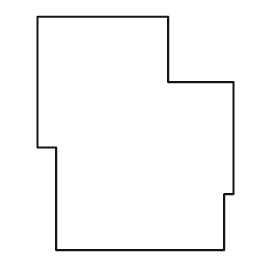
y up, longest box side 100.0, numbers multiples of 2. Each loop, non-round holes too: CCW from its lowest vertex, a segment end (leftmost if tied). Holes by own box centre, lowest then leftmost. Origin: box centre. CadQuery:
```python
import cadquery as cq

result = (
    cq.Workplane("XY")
    .moveTo(-34.0, -50.0)
    .lineTo(38.0, -50.0)
    .lineTo(38.0, -26.0)
    .lineTo(42.0, -26.0)
    .lineTo(42.0, 22.0)
    .lineTo(14.0, 22.0)
    .lineTo(14.0, 50.0)
    .lineTo(-42.0, 50.0)
    .lineTo(-42.0, -6.0)
    .lineTo(-34.0, -6.0)
    .close()
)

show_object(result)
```